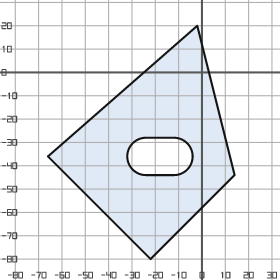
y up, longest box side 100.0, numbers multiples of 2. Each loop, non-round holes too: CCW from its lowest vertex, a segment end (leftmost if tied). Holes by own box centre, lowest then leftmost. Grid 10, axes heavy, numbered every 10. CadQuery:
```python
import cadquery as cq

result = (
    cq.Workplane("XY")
    .moveTo(-22.0, -80.0)
    .lineTo(14.0, -44.0)
    .lineTo(-2.0, 20.0)
    .lineTo(-66.0, -36.0)
    .close()
    .moveTo(-24.0, -44.0)
    .lineTo(-12.0, -44.0)
    .threePointArc((-4.0, -36.0), (-12.0, -28.0))
    .lineTo(-24.0, -28.0)
    .threePointArc((-32.0, -36.0), (-24.0, -44.0))
    .close()
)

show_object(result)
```